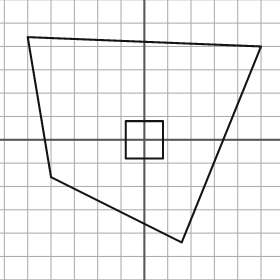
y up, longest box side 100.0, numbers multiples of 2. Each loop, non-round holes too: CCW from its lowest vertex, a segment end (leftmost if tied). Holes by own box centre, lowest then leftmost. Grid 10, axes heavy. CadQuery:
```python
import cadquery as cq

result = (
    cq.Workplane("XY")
    .moveTo(16.0, -44.0)
    .lineTo(50.0, 40.0)
    .lineTo(-50.0, 44.0)
    .lineTo(-40.0, -16.0)
    .close()
    .moveTo(-8.0, -8.0)
    .lineTo(8.0, -8.0)
    .lineTo(8.0, 8.0)
    .lineTo(-8.0, 8.0)
    .close()
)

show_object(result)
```